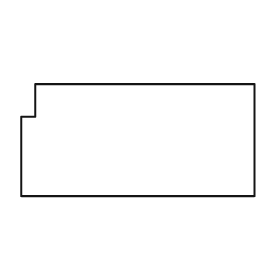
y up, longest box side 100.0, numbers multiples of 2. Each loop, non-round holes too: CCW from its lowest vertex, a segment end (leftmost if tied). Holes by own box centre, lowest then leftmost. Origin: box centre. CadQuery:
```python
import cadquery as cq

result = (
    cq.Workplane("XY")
    .moveTo(-50.0, -24.0)
    .lineTo(50.0, -24.0)
    .lineTo(50.0, 24.0)
    .lineTo(-44.0, 24.0)
    .lineTo(-44.0, 10.0)
    .lineTo(-50.0, 10.0)
    .close()
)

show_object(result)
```